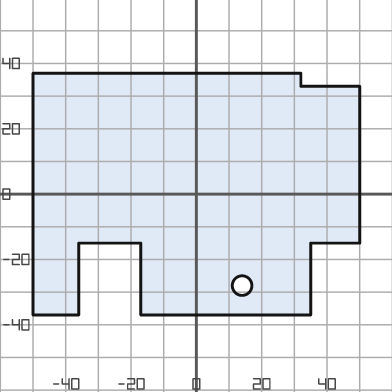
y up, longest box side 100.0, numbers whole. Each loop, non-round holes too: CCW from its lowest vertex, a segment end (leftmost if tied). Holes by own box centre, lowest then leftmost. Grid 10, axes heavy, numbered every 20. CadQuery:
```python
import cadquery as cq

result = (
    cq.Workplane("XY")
    .moveTo(-50.0, -37.0)
    .lineTo(-36.0, -37.0)
    .lineTo(-36.0, -15.0)
    .lineTo(-17.0, -15.0)
    .lineTo(-17.0, -37.0)
    .lineTo(35.0, -37.0)
    .lineTo(35.0, -15.0)
    .lineTo(50.0, -15.0)
    .lineTo(50.0, 33.0)
    .lineTo(32.0, 33.0)
    .lineTo(32.0, 37.0)
    .lineTo(-50.0, 37.0)
    .close()
    .moveTo(14.0, -28.0)
    .circle(3.0)
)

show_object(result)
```